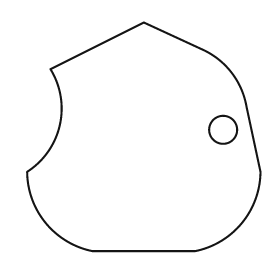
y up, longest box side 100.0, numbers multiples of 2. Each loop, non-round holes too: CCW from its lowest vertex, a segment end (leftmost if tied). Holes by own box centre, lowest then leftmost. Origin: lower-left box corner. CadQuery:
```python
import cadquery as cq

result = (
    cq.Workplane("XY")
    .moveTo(28.0, 0.0)
    .lineTo(72.0, 0.0)
    .threePointArc((92.0, 12.0), (100.0, 34.0))
    .lineTo(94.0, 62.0)
    .threePointArc((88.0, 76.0), (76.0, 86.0))
    .lineTo(50.0, 98.0)
    .lineTo(10.0, 78.0)
    .threePointArc((14.0, 54.0), (0.0, 34.0))
    .threePointArc((8.0, 12.0), (28.0, 0.0))
    .close()
    .moveTo(84.0, 52.0)
    .circle(6.0)
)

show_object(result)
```